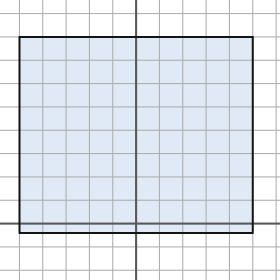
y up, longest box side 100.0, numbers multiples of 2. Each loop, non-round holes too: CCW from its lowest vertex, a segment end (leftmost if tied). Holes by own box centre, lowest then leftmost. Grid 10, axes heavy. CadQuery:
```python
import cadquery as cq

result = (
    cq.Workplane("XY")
    .moveTo(-50.0, -4.0)
    .lineTo(50.0, -4.0)
    .lineTo(50.0, 80.0)
    .lineTo(-50.0, 80.0)
    .close()
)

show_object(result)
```